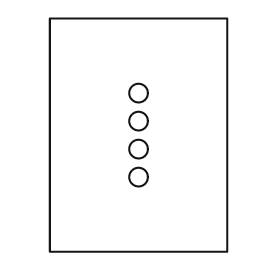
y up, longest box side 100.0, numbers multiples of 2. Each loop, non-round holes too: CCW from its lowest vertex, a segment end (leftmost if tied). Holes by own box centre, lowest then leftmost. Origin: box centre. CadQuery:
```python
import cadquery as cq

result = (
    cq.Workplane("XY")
    .moveTo(-38.0, -50.0)
    .lineTo(38.0, -50.0)
    .lineTo(38.0, 50.0)
    .lineTo(-38.0, 50.0)
    .close()
    .moveTo(0.0, -18.0)
    .circle(4.0)
    .moveTo(0.0, -6.0)
    .circle(4.0)
    .moveTo(0.0, 6.0)
    .circle(4.0)
    .moveTo(0.0, 18.0)
    .circle(4.0)
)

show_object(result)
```